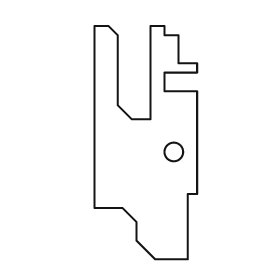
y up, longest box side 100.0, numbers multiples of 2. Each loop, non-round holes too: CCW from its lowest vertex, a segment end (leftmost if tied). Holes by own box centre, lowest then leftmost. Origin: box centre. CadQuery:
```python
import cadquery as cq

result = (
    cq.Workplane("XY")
    .moveTo(4.0, -50.0)
    .lineTo(18.0, -50.0)
    .lineTo(18.0, -22.0)
    .lineTo(22.0, -22.0)
    .lineTo(22.0, 22.0)
    .lineTo(8.0, 22.0)
    .lineTo(8.0, 30.0)
    .lineTo(22.0, 30.0)
    .lineTo(22.0, 34.0)
    .lineTo(14.0, 34.0)
    .lineTo(14.0, 46.0)
    .lineTo(8.0, 46.0)
    .lineTo(8.0, 50.0)
    .lineTo(2.0, 50.0)
    .lineTo(2.0, 10.0)
    .lineTo(-6.0, 10.0)
    .lineTo(-12.0, 16.0)
    .lineTo(-12.0, 46.0)
    .lineTo(-16.0, 50.0)
    .lineTo(-22.0, 50.0)
    .lineTo(-22.0, -28.0)
    .lineTo(-10.0, -28.0)
    .lineTo(-4.0, -34.0)
    .lineTo(-4.0, -42.0)
    .close()
    .moveTo(12.0, -4.0)
    .circle(4.0)
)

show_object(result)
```